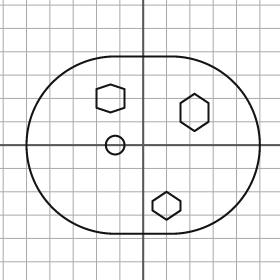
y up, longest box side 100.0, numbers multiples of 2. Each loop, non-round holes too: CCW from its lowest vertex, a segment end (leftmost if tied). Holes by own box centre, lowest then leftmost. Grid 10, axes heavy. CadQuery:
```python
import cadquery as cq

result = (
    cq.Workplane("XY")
    .moveTo(-12.0, -38.0)
    .lineTo(12.0, -38.0)
    .threePointArc((50.0, 0.0), (12.0, 38.0))
    .lineTo(-12.0, 38.0)
    .threePointArc((-50.0, 0.0), (-12.0, -38.0))
    .close()
    .moveTo(10.0, -32.0)
    .lineTo(16.0, -28.0)
    .lineTo(16.0, -24.0)
    .lineTo(10.0, -20.0)
    .lineTo(4.0, -24.0)
    .lineTo(4.0, -28.0)
    .close()
    .moveTo(-12.0, 0.0)
    .circle(4.0)
    .moveTo(22.0, 6.0)
    .lineTo(28.0, 10.0)
    .lineTo(28.0, 18.0)
    .lineTo(22.0, 22.0)
    .lineTo(16.0, 18.0)
    .lineTo(16.0, 10.0)
    .close()
    .moveTo(-14.0, 14.0)
    .lineTo(-8.0, 16.0)
    .lineTo(-8.0, 24.0)
    .lineTo(-14.0, 26.0)
    .lineTo(-20.0, 24.0)
    .lineTo(-20.0, 16.0)
    .close()
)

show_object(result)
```